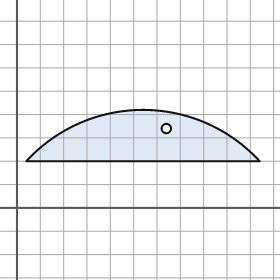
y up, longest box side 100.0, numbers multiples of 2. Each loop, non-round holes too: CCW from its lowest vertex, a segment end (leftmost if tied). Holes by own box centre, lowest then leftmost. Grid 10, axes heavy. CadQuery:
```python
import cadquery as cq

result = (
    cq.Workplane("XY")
    .moveTo(4.0, 20.0)
    .lineTo(104.0, 20.0)
    .threePointArc((54.0, 42.0), (4.0, 20.0))
    .close()
    .moveTo(64.0, 34.0)
    .circle(2.0)
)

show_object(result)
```